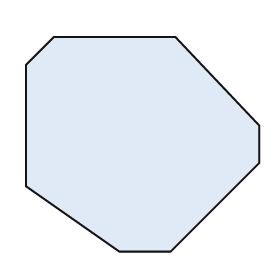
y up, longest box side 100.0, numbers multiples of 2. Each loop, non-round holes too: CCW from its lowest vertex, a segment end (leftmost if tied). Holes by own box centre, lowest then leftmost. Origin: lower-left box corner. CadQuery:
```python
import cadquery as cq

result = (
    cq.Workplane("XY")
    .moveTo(40.0, 0.0)
    .lineTo(62.0, 0.0)
    .lineTo(100.0, 38.0)
    .lineTo(100.0, 54.0)
    .lineTo(64.0, 92.0)
    .lineTo(12.0, 92.0)
    .lineTo(0.0, 80.0)
    .lineTo(0.0, 28.0)
    .close()
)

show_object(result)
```